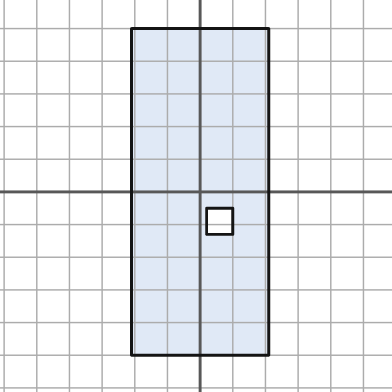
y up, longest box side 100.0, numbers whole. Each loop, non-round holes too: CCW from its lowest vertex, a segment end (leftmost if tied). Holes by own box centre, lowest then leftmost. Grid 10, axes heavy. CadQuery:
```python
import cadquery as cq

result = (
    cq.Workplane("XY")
    .moveTo(-21.0, -50.0)
    .lineTo(21.0, -50.0)
    .lineTo(21.0, 50.0)
    .lineTo(-21.0, 50.0)
    .close()
    .moveTo(2.0, -13.0)
    .lineTo(10.0, -13.0)
    .lineTo(10.0, -5.0)
    .lineTo(2.0, -5.0)
    .close()
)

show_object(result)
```